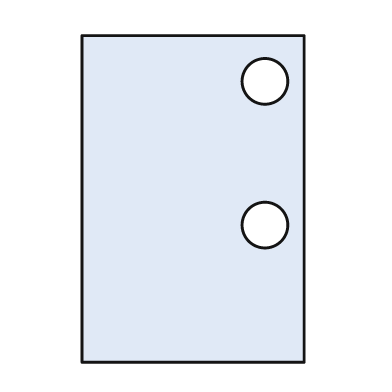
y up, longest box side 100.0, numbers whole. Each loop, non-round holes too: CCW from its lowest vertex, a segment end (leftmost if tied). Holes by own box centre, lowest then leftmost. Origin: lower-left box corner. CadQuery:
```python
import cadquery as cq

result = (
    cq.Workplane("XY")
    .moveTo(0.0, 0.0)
    .lineTo(68.0, 0.0)
    .lineTo(68.0, 100.0)
    .lineTo(0.0, 100.0)
    .close()
    .moveTo(56.0, 42.0)
    .circle(7.0)
    .moveTo(56.0, 86.0)
    .circle(7.0)
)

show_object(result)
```